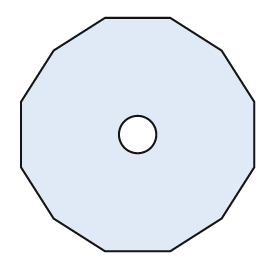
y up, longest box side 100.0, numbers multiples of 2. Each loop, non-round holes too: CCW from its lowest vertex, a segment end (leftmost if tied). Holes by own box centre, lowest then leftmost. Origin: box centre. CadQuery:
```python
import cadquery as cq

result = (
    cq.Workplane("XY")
    .moveTo(-14.0, -50.0)
    .lineTo(14.0, -50.0)
    .lineTo(36.0, -36.0)
    .lineTo(50.0, -14.0)
    .lineTo(50.0, 14.0)
    .lineTo(36.0, 36.0)
    .lineTo(14.0, 50.0)
    .lineTo(-14.0, 50.0)
    .lineTo(-36.0, 36.0)
    .lineTo(-50.0, 14.0)
    .lineTo(-50.0, -14.0)
    .lineTo(-36.0, -36.0)
    .close()
    .moveTo(0.0, 0.0)
    .circle(8.0)
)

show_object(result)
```